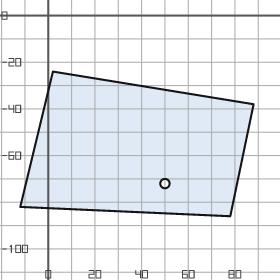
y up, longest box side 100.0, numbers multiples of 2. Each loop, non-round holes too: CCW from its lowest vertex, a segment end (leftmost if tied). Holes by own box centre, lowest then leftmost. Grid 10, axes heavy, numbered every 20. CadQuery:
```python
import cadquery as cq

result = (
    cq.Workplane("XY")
    .moveTo(78.0, -86.0)
    .lineTo(88.0, -38.0)
    .lineTo(2.0, -24.0)
    .lineTo(-12.0, -82.0)
    .close()
    .moveTo(50.0, -72.0)
    .circle(2.0)
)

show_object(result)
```